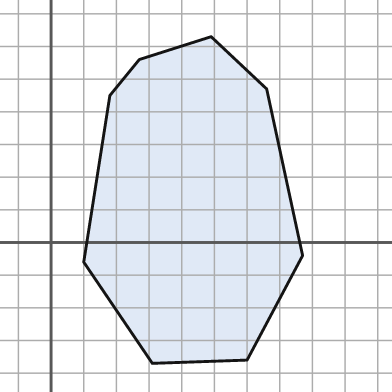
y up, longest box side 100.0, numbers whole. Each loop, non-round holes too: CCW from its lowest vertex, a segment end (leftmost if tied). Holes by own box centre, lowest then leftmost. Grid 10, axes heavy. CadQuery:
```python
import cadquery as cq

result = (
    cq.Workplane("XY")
    .moveTo(31.0, -37.0)
    .lineTo(60.0, -36.0)
    .lineTo(77.0, -4.0)
    .lineTo(66.0, 47.0)
    .lineTo(49.0, 63.0)
    .lineTo(27.0, 56.0)
    .lineTo(18.0, 45.0)
    .lineTo(10.0, -6.0)
    .close()
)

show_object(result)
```